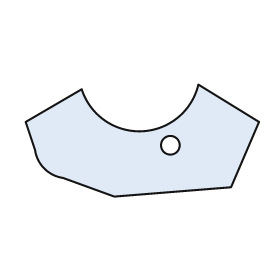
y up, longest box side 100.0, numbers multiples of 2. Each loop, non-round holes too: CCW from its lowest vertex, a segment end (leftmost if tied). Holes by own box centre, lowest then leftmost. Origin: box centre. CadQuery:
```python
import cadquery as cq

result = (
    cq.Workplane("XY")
    .moveTo(-12.0, -24.0)
    .lineTo(38.0, -20.0)
    .lineTo(50.0, 8.0)
    .lineTo(24.0, 24.0)
    .threePointArc((0.0, 4.0), (-26.0, 22.0))
    .lineTo(-50.0, 8.0)
    .lineTo(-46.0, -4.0)
    .threePointArc((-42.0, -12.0), (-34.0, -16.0))
    .close()
    .moveTo(12.0, -2.0)
    .circle(4.0)
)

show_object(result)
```